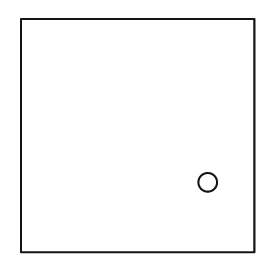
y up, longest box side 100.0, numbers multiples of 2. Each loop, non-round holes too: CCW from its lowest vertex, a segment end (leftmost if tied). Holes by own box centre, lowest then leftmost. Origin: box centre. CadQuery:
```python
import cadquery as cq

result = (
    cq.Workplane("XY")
    .moveTo(-50.0, -50.0)
    .lineTo(50.0, -50.0)
    .lineTo(50.0, 50.0)
    .lineTo(-50.0, 50.0)
    .close()
    .moveTo(30.0, -20.0)
    .circle(4.0)
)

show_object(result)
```